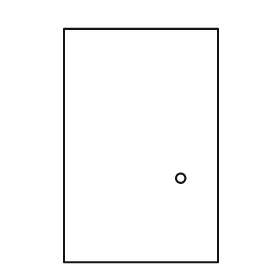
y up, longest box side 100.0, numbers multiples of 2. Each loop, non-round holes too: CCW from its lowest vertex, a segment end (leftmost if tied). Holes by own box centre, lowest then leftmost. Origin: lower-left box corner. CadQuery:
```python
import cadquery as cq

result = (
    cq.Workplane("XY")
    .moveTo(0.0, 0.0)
    .lineTo(66.0, 0.0)
    .lineTo(66.0, 100.0)
    .lineTo(0.0, 100.0)
    .close()
    .moveTo(50.0, 36.0)
    .circle(2.0)
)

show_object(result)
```